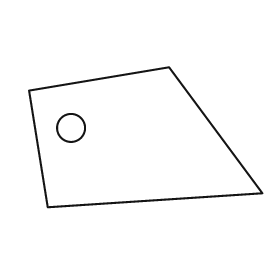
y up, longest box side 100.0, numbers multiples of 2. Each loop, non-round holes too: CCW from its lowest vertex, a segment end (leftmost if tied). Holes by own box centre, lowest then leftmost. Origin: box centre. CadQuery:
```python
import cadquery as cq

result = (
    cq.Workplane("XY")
    .moveTo(-42.0, -30.0)
    .lineTo(50.0, -24.0)
    .lineTo(10.0, 30.0)
    .lineTo(-50.0, 20.0)
    .close()
    .moveTo(-32.0, 4.0)
    .circle(6.0)
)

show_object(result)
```